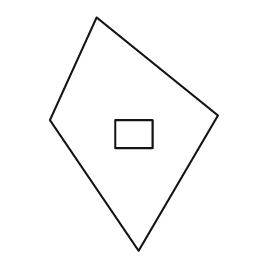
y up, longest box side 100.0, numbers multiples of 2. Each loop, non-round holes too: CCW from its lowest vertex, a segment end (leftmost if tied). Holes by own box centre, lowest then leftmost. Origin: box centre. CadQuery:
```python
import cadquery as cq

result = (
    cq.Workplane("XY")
    .moveTo(2.0, -50.0)
    .lineTo(36.0, 8.0)
    .lineTo(-16.0, 50.0)
    .lineTo(-36.0, 6.0)
    .close()
    .moveTo(-8.0, -6.0)
    .lineTo(8.0, -6.0)
    .lineTo(8.0, 6.0)
    .lineTo(-8.0, 6.0)
    .close()
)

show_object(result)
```